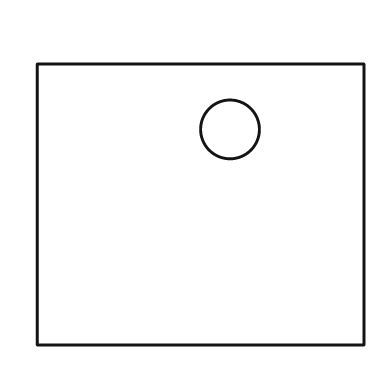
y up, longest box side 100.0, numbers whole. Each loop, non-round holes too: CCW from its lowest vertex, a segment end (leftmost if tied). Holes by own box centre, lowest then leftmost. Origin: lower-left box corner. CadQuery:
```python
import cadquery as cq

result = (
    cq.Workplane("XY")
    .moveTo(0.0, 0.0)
    .lineTo(100.0, 0.0)
    .lineTo(100.0, 86.0)
    .lineTo(0.0, 86.0)
    .close()
    .moveTo(59.0, 66.0)
    .circle(9.0)
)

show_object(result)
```